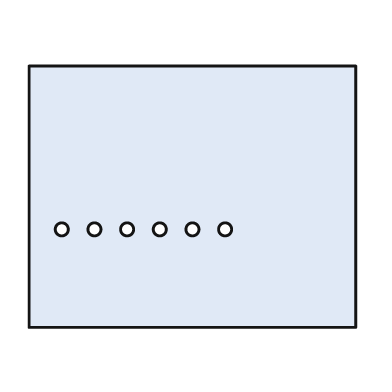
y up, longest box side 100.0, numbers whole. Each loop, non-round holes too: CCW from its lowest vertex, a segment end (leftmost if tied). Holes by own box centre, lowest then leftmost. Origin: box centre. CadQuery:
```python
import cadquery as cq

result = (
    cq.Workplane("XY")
    .moveTo(-50.0, -40.0)
    .lineTo(50.0, -40.0)
    .lineTo(50.0, 40.0)
    .lineTo(-50.0, 40.0)
    .close()
    .moveTo(-40.0, -10.0)
    .circle(2.0)
    .moveTo(-30.0, -10.0)
    .circle(2.0)
    .moveTo(-20.0, -10.0)
    .circle(2.0)
    .moveTo(-10.0, -10.0)
    .circle(2.0)
    .moveTo(0.0, -10.0)
    .circle(2.0)
    .moveTo(10.0, -10.0)
    .circle(2.0)
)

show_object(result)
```